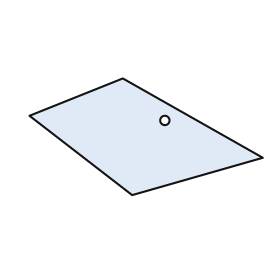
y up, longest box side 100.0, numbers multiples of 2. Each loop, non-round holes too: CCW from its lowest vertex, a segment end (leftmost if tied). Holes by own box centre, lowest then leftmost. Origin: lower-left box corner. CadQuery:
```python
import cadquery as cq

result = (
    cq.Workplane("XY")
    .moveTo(44.0, 0.0)
    .lineTo(100.0, 16.0)
    .lineTo(40.0, 50.0)
    .lineTo(0.0, 34.0)
    .close()
    .moveTo(58.0, 32.0)
    .circle(2.0)
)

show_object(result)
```